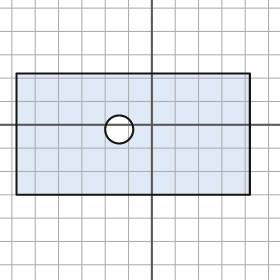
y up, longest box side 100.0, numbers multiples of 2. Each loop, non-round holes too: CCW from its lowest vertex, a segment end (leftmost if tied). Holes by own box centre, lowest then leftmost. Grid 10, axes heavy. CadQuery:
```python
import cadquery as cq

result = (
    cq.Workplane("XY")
    .moveTo(-58.0, -30.0)
    .lineTo(42.0, -30.0)
    .lineTo(42.0, 22.0)
    .lineTo(-58.0, 22.0)
    .close()
    .moveTo(-14.0, -2.0)
    .circle(6.0)
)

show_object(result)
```